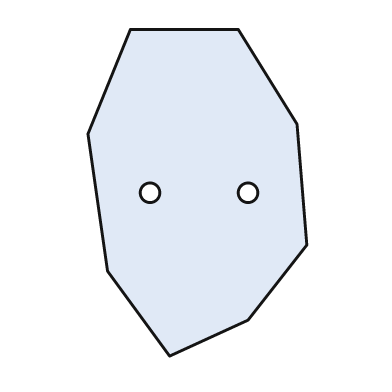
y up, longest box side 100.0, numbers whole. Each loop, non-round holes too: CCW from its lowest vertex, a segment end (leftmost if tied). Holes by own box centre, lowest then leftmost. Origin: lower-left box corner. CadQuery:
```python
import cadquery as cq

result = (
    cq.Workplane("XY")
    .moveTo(25.0, 0.0)
    .lineTo(49.0, 11.0)
    .lineTo(67.0, 34.0)
    .lineTo(64.0, 71.0)
    .lineTo(46.0, 100.0)
    .lineTo(13.0, 100.0)
    .lineTo(0.0, 68.0)
    .lineTo(6.0, 26.0)
    .close()
    .moveTo(19.0, 50.0)
    .circle(3.0)
    .moveTo(49.0, 50.0)
    .circle(3.0)
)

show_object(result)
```